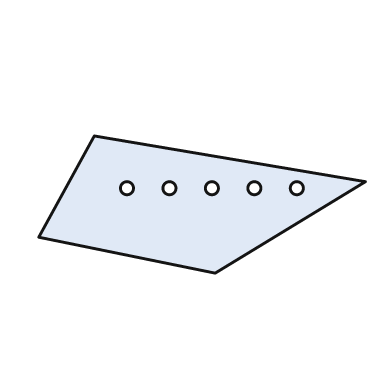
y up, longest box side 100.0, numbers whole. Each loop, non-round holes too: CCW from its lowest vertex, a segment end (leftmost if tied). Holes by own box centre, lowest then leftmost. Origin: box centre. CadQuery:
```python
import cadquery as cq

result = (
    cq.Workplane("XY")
    .moveTo(4.0, -21.0)
    .lineTo(50.0, 7.0)
    .lineTo(-33.0, 21.0)
    .lineTo(-50.0, -10.0)
    .close()
    .moveTo(-23.0, 5.0)
    .circle(2.0)
    .moveTo(-10.0, 5.0)
    .circle(2.0)
    .moveTo(3.0, 5.0)
    .circle(2.0)
    .moveTo(16.0, 5.0)
    .circle(2.0)
    .moveTo(29.0, 5.0)
    .circle(2.0)
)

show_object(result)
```